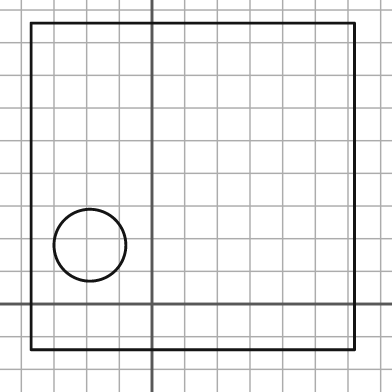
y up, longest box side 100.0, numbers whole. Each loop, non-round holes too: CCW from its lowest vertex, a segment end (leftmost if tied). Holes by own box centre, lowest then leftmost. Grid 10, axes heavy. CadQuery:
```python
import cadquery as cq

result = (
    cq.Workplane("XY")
    .moveTo(-37.0, -14.0)
    .lineTo(62.0, -14.0)
    .lineTo(62.0, 86.0)
    .lineTo(-37.0, 86.0)
    .close()
    .moveTo(-19.0, 18.0)
    .circle(11.0)
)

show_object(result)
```